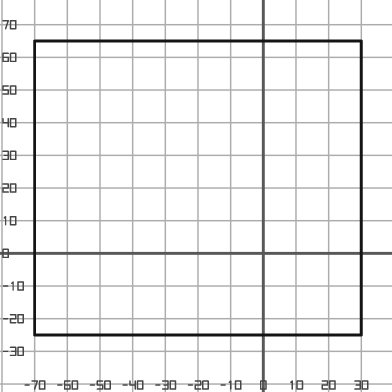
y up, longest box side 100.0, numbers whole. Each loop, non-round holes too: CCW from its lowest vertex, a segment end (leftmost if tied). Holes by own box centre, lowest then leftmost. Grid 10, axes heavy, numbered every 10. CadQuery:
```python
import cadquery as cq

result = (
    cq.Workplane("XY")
    .moveTo(-70.0, -25.0)
    .lineTo(30.0, -25.0)
    .lineTo(30.0, 65.0)
    .lineTo(-70.0, 65.0)
    .close()
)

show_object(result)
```